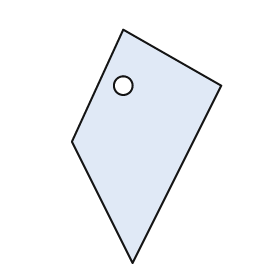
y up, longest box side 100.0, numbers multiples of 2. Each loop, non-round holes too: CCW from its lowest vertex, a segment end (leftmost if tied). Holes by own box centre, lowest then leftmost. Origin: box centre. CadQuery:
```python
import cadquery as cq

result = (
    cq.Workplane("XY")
    .moveTo(-6.0, -50.0)
    .lineTo(32.0, 26.0)
    .lineTo(-10.0, 50.0)
    .lineTo(-32.0, 2.0)
    .close()
    .moveTo(-10.0, 26.0)
    .circle(4.0)
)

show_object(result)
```